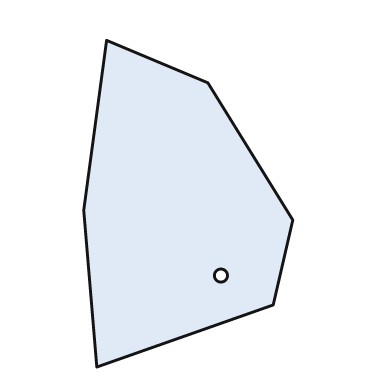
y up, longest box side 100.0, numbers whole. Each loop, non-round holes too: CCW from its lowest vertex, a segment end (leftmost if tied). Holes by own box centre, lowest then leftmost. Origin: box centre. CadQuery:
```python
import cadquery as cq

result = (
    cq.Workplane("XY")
    .moveTo(-28.0, -50.0)
    .lineTo(26.0, -31.0)
    .lineTo(32.0, -5.0)
    .lineTo(6.0, 37.0)
    .lineTo(-25.0, 50.0)
    .lineTo(-32.0, -2.0)
    .close()
    .moveTo(10.0, -22.0)
    .circle(2.0)
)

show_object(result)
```